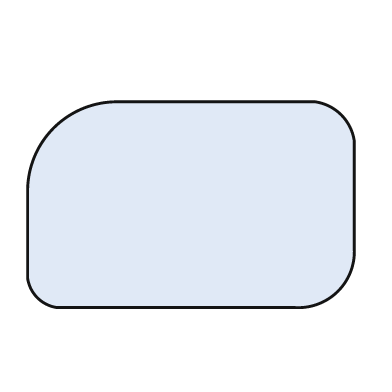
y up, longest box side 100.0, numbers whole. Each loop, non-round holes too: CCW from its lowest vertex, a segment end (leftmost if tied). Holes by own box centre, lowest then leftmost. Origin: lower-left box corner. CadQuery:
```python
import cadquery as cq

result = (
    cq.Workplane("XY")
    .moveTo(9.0, 0.0)
    .lineTo(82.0, 0.0)
    .threePointArc((95.0, 5.0), (100.0, 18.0))
    .lineTo(100.0, 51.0)
    .threePointArc((96.0, 59.0), (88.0, 63.0))
    .lineTo(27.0, 63.0)
    .threePointArc((8.0, 55.0), (0.0, 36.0))
    .lineTo(0.0, 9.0)
    .threePointArc((3.0, 3.0), (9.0, 0.0))
    .close()
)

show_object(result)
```